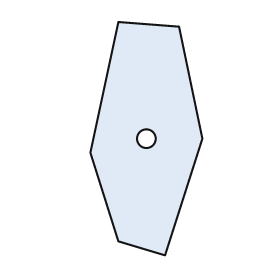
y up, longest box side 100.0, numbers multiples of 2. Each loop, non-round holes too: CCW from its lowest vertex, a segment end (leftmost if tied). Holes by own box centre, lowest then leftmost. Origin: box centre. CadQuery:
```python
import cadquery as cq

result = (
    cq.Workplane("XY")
    .moveTo(8.0, -50.0)
    .lineTo(24.0, 0.0)
    .lineTo(14.0, 48.0)
    .lineTo(-12.0, 50.0)
    .lineTo(-24.0, -6.0)
    .lineTo(-12.0, -44.0)
    .close()
    .moveTo(0.0, 0.0)
    .circle(4.0)
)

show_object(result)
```